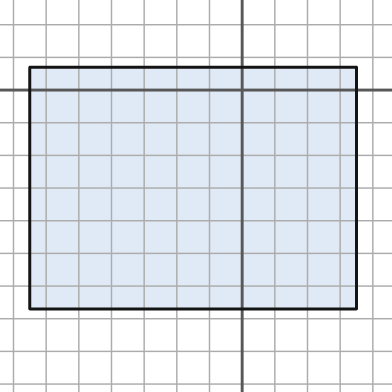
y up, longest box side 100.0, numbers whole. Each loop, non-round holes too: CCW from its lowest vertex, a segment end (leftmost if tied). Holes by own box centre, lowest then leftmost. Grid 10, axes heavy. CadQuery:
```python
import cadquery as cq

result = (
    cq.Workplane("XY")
    .moveTo(-65.0, -67.0)
    .lineTo(35.0, -67.0)
    .lineTo(35.0, 7.0)
    .lineTo(-65.0, 7.0)
    .close()
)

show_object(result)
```